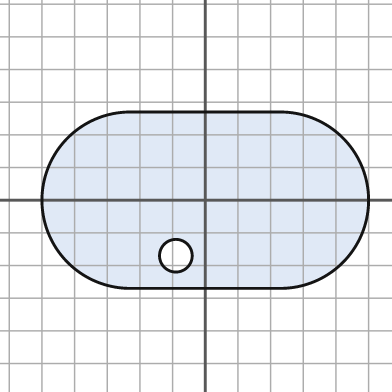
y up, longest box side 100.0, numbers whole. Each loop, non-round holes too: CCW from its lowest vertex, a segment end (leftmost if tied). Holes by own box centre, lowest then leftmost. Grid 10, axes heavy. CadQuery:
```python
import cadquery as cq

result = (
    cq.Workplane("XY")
    .moveTo(-23.0, -27.0)
    .lineTo(23.0, -27.0)
    .threePointArc((50.0, 0.0), (23.0, 27.0))
    .lineTo(-23.0, 27.0)
    .threePointArc((-50.0, 0.0), (-23.0, -27.0))
    .close()
    .moveTo(-9.0, -17.0)
    .circle(5.0)
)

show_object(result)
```